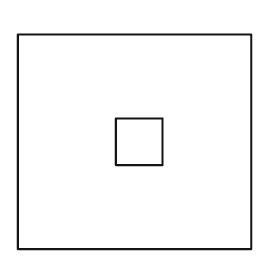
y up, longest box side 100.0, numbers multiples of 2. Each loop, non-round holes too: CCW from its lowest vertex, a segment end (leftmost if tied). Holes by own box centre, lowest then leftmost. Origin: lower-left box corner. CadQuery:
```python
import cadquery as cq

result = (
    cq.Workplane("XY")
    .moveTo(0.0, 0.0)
    .lineTo(100.0, 0.0)
    .lineTo(100.0, 92.0)
    .lineTo(0.0, 92.0)
    .close()
    .moveTo(42.0, 36.0)
    .lineTo(62.0, 36.0)
    .lineTo(62.0, 56.0)
    .lineTo(42.0, 56.0)
    .close()
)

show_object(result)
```